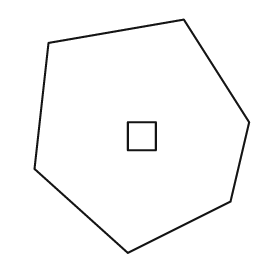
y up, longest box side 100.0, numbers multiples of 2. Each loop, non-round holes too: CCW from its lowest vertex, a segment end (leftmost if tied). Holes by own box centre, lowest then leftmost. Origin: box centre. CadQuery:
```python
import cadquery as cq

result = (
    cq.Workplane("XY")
    .moveTo(-6.0, -50.0)
    .lineTo(38.0, -28.0)
    .lineTo(46.0, 6.0)
    .lineTo(18.0, 50.0)
    .lineTo(-40.0, 40.0)
    .lineTo(-46.0, -14.0)
    .close()
    .moveTo(-6.0, -6.0)
    .lineTo(6.0, -6.0)
    .lineTo(6.0, 6.0)
    .lineTo(-6.0, 6.0)
    .close()
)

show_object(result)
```